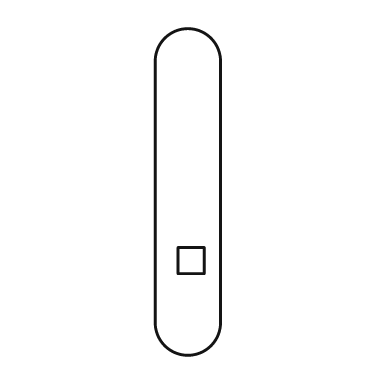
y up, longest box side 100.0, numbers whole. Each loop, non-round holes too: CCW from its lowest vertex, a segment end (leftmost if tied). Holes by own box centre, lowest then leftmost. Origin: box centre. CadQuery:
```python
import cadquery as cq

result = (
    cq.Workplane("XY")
    .moveTo(-10.0, -40.0)
    .threePointArc((0.0, -50.0), (10.0, -40.0))
    .lineTo(10.0, 40.0)
    .threePointArc((0.0, 50.0), (-10.0, 40.0))
    .close()
    .moveTo(-3.0, -25.0)
    .lineTo(5.0, -25.0)
    .lineTo(5.0, -17.0)
    .lineTo(-3.0, -17.0)
    .close()
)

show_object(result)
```